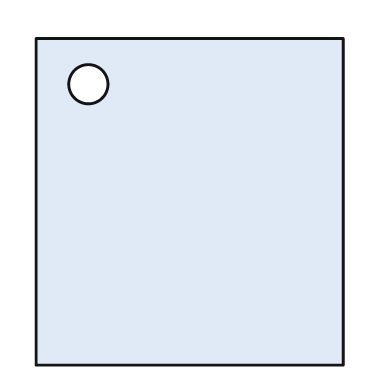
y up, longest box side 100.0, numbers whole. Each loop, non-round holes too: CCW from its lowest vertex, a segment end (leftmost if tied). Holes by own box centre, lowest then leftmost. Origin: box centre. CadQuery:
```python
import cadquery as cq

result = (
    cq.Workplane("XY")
    .moveTo(-47.0, -50.0)
    .lineTo(47.0, -50.0)
    .lineTo(47.0, 50.0)
    .lineTo(-47.0, 50.0)
    .close()
    .moveTo(-31.0, 36.0)
    .circle(6.0)
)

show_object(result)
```